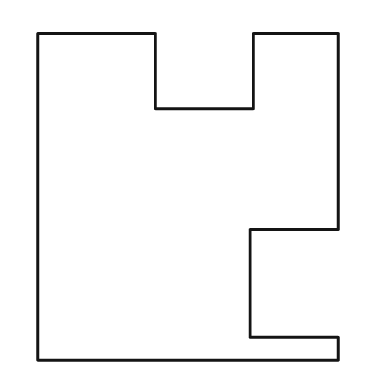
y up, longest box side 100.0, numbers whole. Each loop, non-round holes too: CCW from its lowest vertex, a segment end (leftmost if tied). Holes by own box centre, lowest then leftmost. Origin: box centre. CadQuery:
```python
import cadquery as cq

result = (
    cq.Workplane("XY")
    .moveTo(-46.0, -50.0)
    .lineTo(46.0, -50.0)
    .lineTo(46.0, -43.0)
    .lineTo(19.0, -43.0)
    .lineTo(19.0, -10.0)
    .lineTo(46.0, -10.0)
    .lineTo(46.0, 50.0)
    .lineTo(20.0, 50.0)
    .lineTo(20.0, 27.0)
    .lineTo(-10.0, 27.0)
    .lineTo(-10.0, 50.0)
    .lineTo(-46.0, 50.0)
    .close()
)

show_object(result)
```